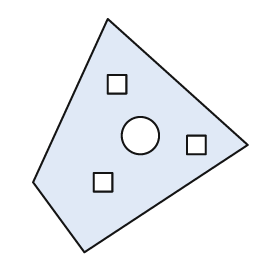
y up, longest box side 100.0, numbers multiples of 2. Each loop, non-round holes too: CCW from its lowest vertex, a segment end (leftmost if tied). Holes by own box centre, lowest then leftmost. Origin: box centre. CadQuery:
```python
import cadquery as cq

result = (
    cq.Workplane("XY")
    .moveTo(-24.0, -50.0)
    .lineTo(46.0, -4.0)
    .lineTo(-14.0, 50.0)
    .lineTo(-46.0, -20.0)
    .close()
    .moveTo(-20.0, -24.0)
    .lineTo(-12.0, -24.0)
    .lineTo(-12.0, -16.0)
    .lineTo(-20.0, -16.0)
    .close()
    .moveTo(20.0, -8.0)
    .lineTo(28.0, -8.0)
    .lineTo(28.0, 0.0)
    .lineTo(20.0, 0.0)
    .close()
    .moveTo(0.0, 0.0)
    .circle(8.0)
    .moveTo(-14.0, 18.0)
    .lineTo(-6.0, 18.0)
    .lineTo(-6.0, 26.0)
    .lineTo(-14.0, 26.0)
    .close()
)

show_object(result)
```